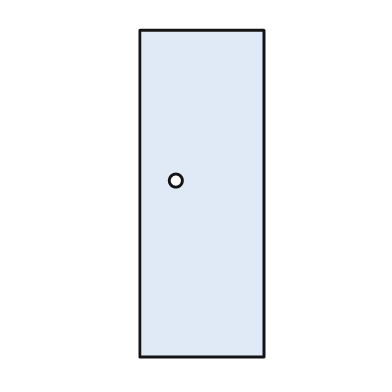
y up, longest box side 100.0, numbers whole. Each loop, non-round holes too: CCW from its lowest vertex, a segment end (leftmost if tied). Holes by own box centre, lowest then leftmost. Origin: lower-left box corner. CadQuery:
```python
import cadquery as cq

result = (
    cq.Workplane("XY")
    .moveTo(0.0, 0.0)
    .lineTo(38.0, 0.0)
    .lineTo(38.0, 100.0)
    .lineTo(0.0, 100.0)
    .close()
    .moveTo(11.0, 54.0)
    .circle(2.0)
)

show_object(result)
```